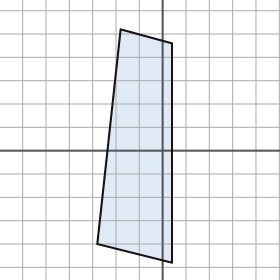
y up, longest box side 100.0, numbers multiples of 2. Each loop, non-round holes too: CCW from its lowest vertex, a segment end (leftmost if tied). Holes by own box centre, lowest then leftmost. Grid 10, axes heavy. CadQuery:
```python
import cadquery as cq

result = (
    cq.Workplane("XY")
    .moveTo(4.0, -48.0)
    .lineTo(4.0, 46.0)
    .lineTo(-18.0, 52.0)
    .lineTo(-28.0, -40.0)
    .close()
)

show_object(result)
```